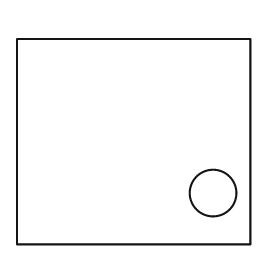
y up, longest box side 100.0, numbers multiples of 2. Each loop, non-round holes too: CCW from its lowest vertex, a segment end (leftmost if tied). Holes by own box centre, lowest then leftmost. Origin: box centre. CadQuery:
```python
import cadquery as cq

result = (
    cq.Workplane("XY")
    .moveTo(-50.0, -44.0)
    .lineTo(50.0, -44.0)
    .lineTo(50.0, 44.0)
    .lineTo(-50.0, 44.0)
    .close()
    .moveTo(34.0, -22.0)
    .circle(10.0)
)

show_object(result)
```